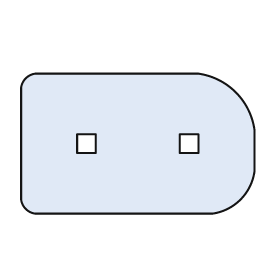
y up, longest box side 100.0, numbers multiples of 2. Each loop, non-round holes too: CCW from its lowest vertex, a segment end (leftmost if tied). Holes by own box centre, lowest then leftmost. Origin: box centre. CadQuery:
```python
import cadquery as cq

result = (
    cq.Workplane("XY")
    .moveTo(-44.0, -30.0)
    .lineTo(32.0, -30.0)
    .threePointArc((44.0, -24.0), (50.0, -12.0))
    .lineTo(50.0, 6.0)
    .threePointArc((42.0, 22.0), (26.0, 30.0))
    .lineTo(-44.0, 30.0)
    .threePointArc((-48.0, 28.0), (-50.0, 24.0))
    .lineTo(-50.0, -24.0)
    .threePointArc((-48.0, -28.0), (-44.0, -30.0))
    .close()
    .moveTo(-26.0, -4.0)
    .lineTo(-18.0, -4.0)
    .lineTo(-18.0, 4.0)
    .lineTo(-26.0, 4.0)
    .close()
    .moveTo(18.0, -4.0)
    .lineTo(26.0, -4.0)
    .lineTo(26.0, 4.0)
    .lineTo(18.0, 4.0)
    .close()
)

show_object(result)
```